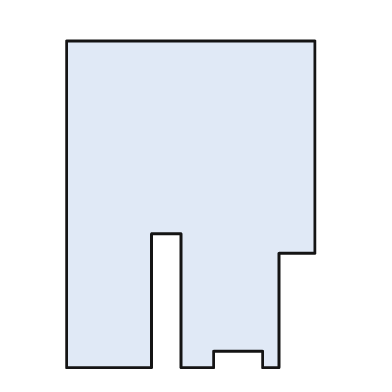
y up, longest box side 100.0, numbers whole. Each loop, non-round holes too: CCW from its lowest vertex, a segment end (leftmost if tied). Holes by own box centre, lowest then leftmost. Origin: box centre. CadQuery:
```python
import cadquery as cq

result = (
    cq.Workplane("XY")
    .moveTo(-38.0, -50.0)
    .lineTo(-12.0, -50.0)
    .lineTo(-12.0, -9.0)
    .lineTo(-3.0, -9.0)
    .lineTo(-3.0, -50.0)
    .lineTo(7.0, -50.0)
    .lineTo(7.0, -45.0)
    .lineTo(22.0, -45.0)
    .lineTo(22.0, -50.0)
    .lineTo(27.0, -50.0)
    .lineTo(27.0, -15.0)
    .lineTo(38.0, -15.0)
    .lineTo(38.0, 50.0)
    .lineTo(-38.0, 50.0)
    .close()
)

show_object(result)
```